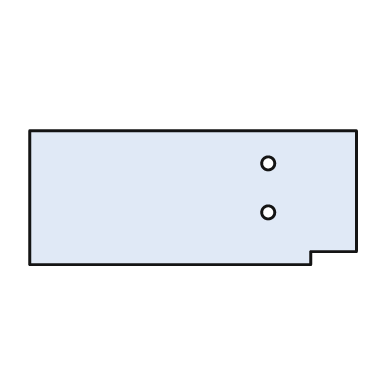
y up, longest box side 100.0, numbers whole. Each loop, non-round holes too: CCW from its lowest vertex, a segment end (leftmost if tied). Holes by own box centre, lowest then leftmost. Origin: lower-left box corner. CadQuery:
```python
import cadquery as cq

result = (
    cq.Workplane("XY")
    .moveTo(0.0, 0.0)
    .lineTo(86.0, 0.0)
    .lineTo(86.0, 4.0)
    .lineTo(100.0, 4.0)
    .lineTo(100.0, 41.0)
    .lineTo(0.0, 41.0)
    .close()
    .moveTo(73.0, 16.0)
    .circle(2.0)
    .moveTo(73.0, 31.0)
    .circle(2.0)
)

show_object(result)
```